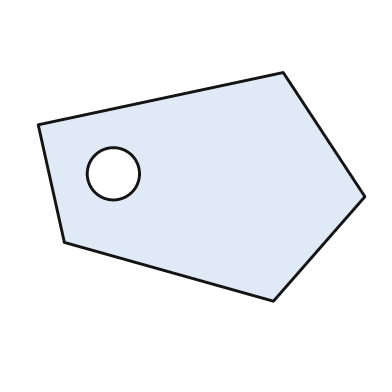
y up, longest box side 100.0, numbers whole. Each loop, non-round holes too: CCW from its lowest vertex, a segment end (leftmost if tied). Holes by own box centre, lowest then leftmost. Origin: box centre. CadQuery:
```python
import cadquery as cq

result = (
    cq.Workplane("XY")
    .moveTo(22.0, -35.0)
    .lineTo(50.0, -3.0)
    .lineTo(25.0, 35.0)
    .lineTo(-50.0, 19.0)
    .lineTo(-42.0, -17.0)
    .close()
    .moveTo(-27.0, 4.0)
    .circle(8.0)
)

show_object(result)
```